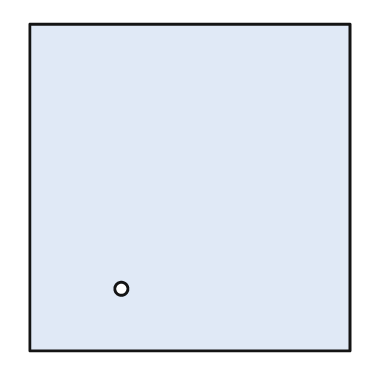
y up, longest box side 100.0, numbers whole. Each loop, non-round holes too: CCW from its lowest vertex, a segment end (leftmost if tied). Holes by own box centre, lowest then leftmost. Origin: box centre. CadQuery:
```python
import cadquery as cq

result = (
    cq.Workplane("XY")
    .moveTo(-49.0, -50.0)
    .lineTo(49.0, -50.0)
    .lineTo(49.0, 50.0)
    .lineTo(-49.0, 50.0)
    .close()
    .moveTo(-21.0, -31.0)
    .circle(2.0)
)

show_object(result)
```